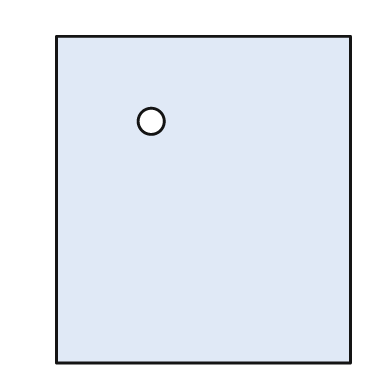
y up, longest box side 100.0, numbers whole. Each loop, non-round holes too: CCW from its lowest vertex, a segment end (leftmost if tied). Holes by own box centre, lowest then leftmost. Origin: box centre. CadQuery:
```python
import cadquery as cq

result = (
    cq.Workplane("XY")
    .moveTo(-45.0, -50.0)
    .lineTo(45.0, -50.0)
    .lineTo(45.0, 50.0)
    .lineTo(-45.0, 50.0)
    .close()
    .moveTo(-16.0, 24.0)
    .circle(4.0)
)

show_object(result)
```